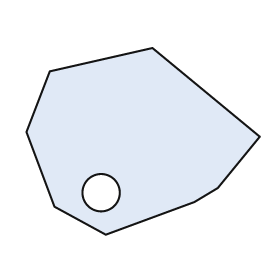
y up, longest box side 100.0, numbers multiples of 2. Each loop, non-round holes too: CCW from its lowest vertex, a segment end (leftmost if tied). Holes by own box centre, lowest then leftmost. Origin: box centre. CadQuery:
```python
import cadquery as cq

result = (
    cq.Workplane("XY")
    .moveTo(-16.0, -40.0)
    .lineTo(22.0, -26.0)
    .lineTo(32.0, -20.0)
    .lineTo(50.0, 2.0)
    .lineTo(4.0, 40.0)
    .lineTo(-40.0, 30.0)
    .lineTo(-50.0, 4.0)
    .lineTo(-38.0, -28.0)
    .close()
    .moveTo(-18.0, -22.0)
    .circle(8.0)
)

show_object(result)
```